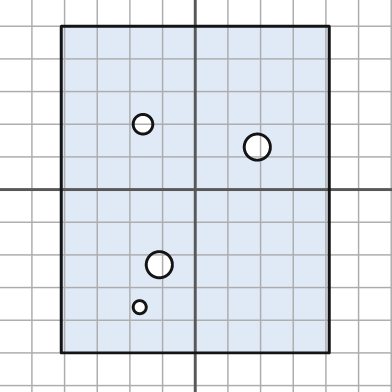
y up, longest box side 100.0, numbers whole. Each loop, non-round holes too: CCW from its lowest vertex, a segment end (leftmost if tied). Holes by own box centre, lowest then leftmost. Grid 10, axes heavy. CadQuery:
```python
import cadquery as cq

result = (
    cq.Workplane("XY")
    .moveTo(-41.0, -50.0)
    .lineTo(41.0, -50.0)
    .lineTo(41.0, 50.0)
    .lineTo(-41.0, 50.0)
    .close()
    .moveTo(-17.0, -36.0)
    .circle(2.0)
    .moveTo(-11.0, -23.0)
    .circle(4.0)
    .moveTo(19.0, 13.0)
    .circle(4.0)
    .moveTo(-16.0, 20.0)
    .circle(3.0)
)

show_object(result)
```